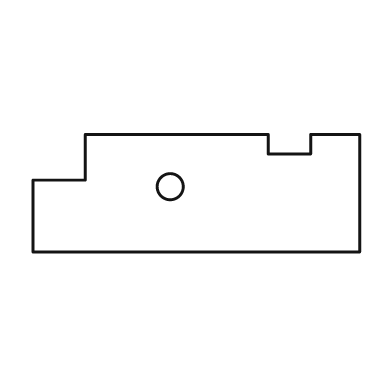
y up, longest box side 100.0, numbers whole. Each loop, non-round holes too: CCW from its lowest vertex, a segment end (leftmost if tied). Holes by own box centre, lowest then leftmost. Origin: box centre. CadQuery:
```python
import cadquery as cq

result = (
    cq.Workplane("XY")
    .moveTo(-50.0, -18.0)
    .lineTo(50.0, -18.0)
    .lineTo(50.0, 18.0)
    .lineTo(35.0, 18.0)
    .lineTo(35.0, 12.0)
    .lineTo(22.0, 12.0)
    .lineTo(22.0, 18.0)
    .lineTo(-34.0, 18.0)
    .lineTo(-34.0, 4.0)
    .lineTo(-50.0, 4.0)
    .close()
    .moveTo(-8.0, 2.0)
    .circle(4.0)
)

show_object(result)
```